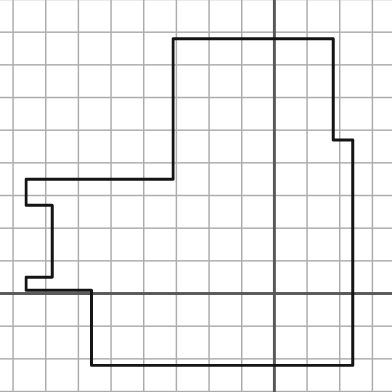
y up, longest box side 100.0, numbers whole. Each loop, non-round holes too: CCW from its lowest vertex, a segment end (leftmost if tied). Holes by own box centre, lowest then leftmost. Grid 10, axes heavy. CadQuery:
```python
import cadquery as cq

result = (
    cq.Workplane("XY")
    .moveTo(-56.0, -22.0)
    .lineTo(24.0, -22.0)
    .lineTo(24.0, 47.0)
    .lineTo(18.0, 47.0)
    .lineTo(18.0, 78.0)
    .lineTo(-31.0, 78.0)
    .lineTo(-31.0, 35.0)
    .lineTo(-76.0, 35.0)
    .lineTo(-76.0, 27.0)
    .lineTo(-68.0, 27.0)
    .lineTo(-68.0, 5.0)
    .lineTo(-76.0, 5.0)
    .lineTo(-76.0, 1.0)
    .lineTo(-56.0, 1.0)
    .close()
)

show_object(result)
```